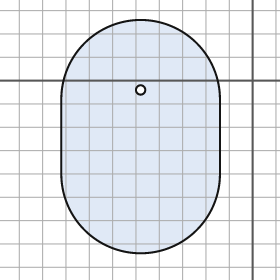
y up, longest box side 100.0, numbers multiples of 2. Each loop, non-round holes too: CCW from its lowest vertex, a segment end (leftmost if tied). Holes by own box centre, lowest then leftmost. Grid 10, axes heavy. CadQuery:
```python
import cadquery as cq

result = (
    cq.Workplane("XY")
    .moveTo(-82.0, -40.0)
    .threePointArc((-48.0, -74.0), (-14.0, -40.0))
    .lineTo(-14.0, -8.0)
    .threePointArc((-48.0, 26.0), (-82.0, -8.0))
    .close()
    .moveTo(-48.0, -4.0)
    .circle(2.0)
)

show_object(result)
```